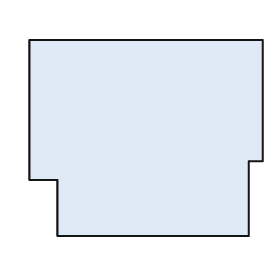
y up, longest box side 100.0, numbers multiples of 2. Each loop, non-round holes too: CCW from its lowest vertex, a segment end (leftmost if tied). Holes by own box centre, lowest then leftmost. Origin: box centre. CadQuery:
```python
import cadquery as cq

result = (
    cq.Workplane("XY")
    .moveTo(-38.0, -42.0)
    .lineTo(44.0, -42.0)
    .lineTo(44.0, -10.0)
    .lineTo(50.0, -10.0)
    .lineTo(50.0, 42.0)
    .lineTo(-50.0, 42.0)
    .lineTo(-50.0, -18.0)
    .lineTo(-38.0, -18.0)
    .close()
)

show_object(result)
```